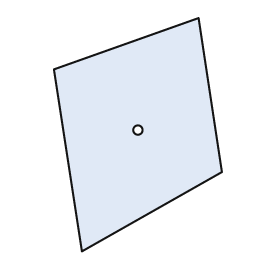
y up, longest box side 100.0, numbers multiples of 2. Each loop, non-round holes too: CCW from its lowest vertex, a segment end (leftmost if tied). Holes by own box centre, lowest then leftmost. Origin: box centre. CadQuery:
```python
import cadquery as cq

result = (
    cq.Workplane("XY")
    .moveTo(-24.0, -50.0)
    .lineTo(36.0, -16.0)
    .lineTo(26.0, 50.0)
    .lineTo(-36.0, 28.0)
    .close()
    .moveTo(0.0, 2.0)
    .circle(2.0)
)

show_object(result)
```